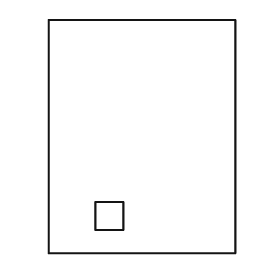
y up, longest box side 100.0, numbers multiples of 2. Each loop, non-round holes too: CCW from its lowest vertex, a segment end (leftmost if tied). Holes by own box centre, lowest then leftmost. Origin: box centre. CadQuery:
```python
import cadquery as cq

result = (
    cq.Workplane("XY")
    .moveTo(-40.0, -50.0)
    .lineTo(40.0, -50.0)
    .lineTo(40.0, 50.0)
    .lineTo(-40.0, 50.0)
    .close()
    .moveTo(-20.0, -40.0)
    .lineTo(-8.0, -40.0)
    .lineTo(-8.0, -28.0)
    .lineTo(-20.0, -28.0)
    .close()
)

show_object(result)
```